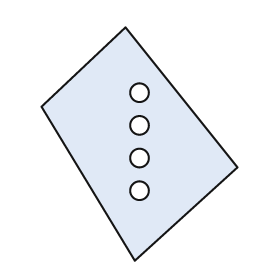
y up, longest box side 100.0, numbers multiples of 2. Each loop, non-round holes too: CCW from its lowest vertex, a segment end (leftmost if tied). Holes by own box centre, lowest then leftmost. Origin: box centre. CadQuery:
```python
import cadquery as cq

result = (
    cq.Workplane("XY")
    .moveTo(-2.0, -50.0)
    .lineTo(42.0, -10.0)
    .lineTo(-6.0, 50.0)
    .lineTo(-42.0, 16.0)
    .close()
    .moveTo(0.0, -20.0)
    .circle(4.0)
    .moveTo(0.0, -6.0)
    .circle(4.0)
    .moveTo(0.0, 8.0)
    .circle(4.0)
    .moveTo(0.0, 22.0)
    .circle(4.0)
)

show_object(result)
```